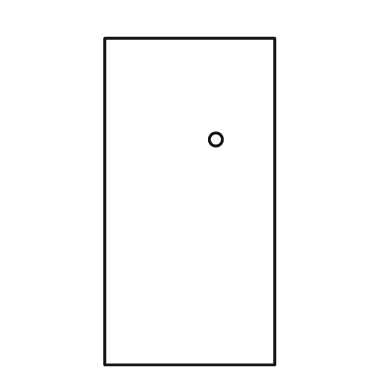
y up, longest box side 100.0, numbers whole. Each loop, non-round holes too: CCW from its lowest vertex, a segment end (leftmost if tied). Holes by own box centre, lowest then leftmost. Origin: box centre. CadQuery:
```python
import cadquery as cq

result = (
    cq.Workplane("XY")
    .moveTo(-26.0, -50.0)
    .lineTo(26.0, -50.0)
    .lineTo(26.0, 50.0)
    .lineTo(-26.0, 50.0)
    .close()
    .moveTo(8.0, 19.0)
    .circle(2.0)
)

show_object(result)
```